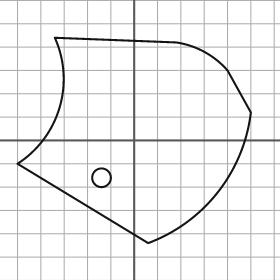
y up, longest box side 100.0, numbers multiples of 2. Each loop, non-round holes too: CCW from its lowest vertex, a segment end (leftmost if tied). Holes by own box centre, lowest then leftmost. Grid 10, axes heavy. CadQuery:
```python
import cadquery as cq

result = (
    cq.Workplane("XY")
    .moveTo(6.0, -44.0)
    .threePointArc((36.0, -22.0), (50.0, 12.0))
    .lineTo(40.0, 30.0)
    .threePointArc((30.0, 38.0), (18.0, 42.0))
    .lineTo(-34.0, 44.0)
    .threePointArc((-32.0, 14.0), (-50.0, -10.0))
    .close()
    .moveTo(-14.0, -16.0)
    .circle(4.0)
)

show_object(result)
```